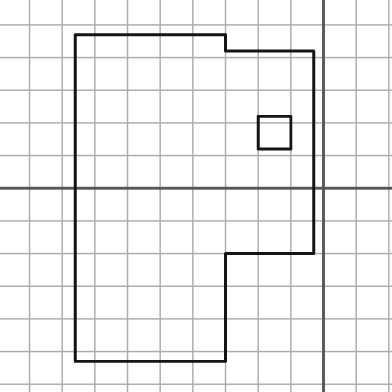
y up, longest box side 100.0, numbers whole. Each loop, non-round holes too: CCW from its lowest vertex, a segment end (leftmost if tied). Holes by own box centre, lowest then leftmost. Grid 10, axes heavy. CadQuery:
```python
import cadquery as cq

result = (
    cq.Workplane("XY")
    .moveTo(-76.0, -53.0)
    .lineTo(-30.0, -53.0)
    .lineTo(-30.0, -20.0)
    .lineTo(-3.0, -20.0)
    .lineTo(-3.0, 42.0)
    .lineTo(-30.0, 42.0)
    .lineTo(-30.0, 47.0)
    .lineTo(-76.0, 47.0)
    .close()
    .moveTo(-20.0, 12.0)
    .lineTo(-10.0, 12.0)
    .lineTo(-10.0, 22.0)
    .lineTo(-20.0, 22.0)
    .close()
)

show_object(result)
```